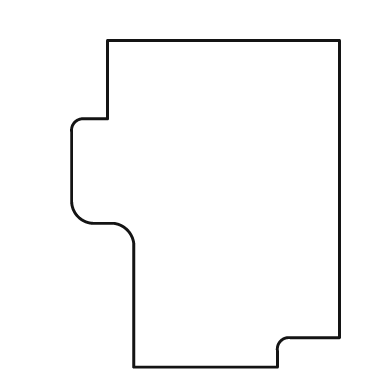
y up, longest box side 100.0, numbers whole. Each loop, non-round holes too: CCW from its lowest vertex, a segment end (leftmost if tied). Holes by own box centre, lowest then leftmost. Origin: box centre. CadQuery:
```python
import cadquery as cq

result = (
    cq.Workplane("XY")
    .moveTo(-22.0, -50.0)
    .lineTo(22.0, -50.0)
    .lineTo(22.0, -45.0)
    .threePointArc((23.0, -42.0), (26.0, -41.0))
    .lineTo(41.0, -41.0)
    .lineTo(41.0, 50.0)
    .lineTo(-30.0, 50.0)
    .lineTo(-30.0, 26.0)
    .lineTo(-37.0, 26.0)
    .threePointArc((-40.0, 25.0), (-41.0, 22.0))
    .lineTo(-41.0, 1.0)
    .threePointArc((-39.0, -4.0), (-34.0, -6.0))
    .lineTo(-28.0, -6.0)
    .threePointArc((-24.0, -8.0), (-22.0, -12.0))
    .close()
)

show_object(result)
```